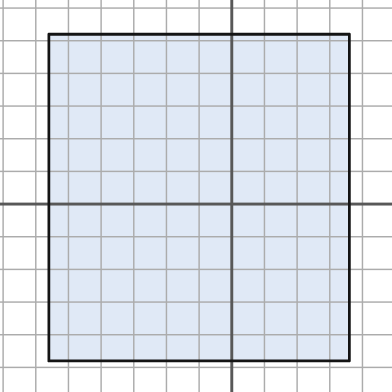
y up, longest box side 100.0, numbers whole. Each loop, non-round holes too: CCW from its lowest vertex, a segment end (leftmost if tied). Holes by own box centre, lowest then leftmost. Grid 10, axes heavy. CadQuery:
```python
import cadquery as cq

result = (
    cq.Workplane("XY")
    .moveTo(-56.0, -48.0)
    .lineTo(36.0, -48.0)
    .lineTo(36.0, 52.0)
    .lineTo(-56.0, 52.0)
    .close()
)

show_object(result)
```